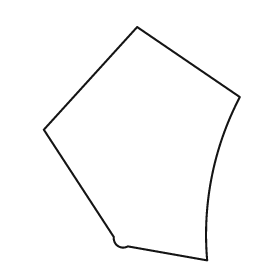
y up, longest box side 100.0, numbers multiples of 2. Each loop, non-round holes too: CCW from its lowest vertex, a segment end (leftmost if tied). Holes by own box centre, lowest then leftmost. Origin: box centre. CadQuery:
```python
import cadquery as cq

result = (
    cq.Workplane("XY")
    .moveTo(28.0, -50.0)
    .threePointArc((30.0, -14.0), (42.0, 20.0))
    .lineTo(-2.0, 50.0)
    .lineTo(-42.0, 6.0)
    .lineTo(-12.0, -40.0)
    .threePointArc((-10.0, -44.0), (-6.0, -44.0))
    .close()
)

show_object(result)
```